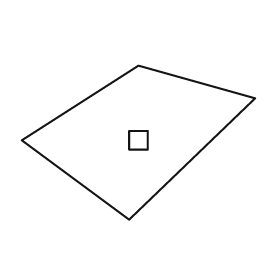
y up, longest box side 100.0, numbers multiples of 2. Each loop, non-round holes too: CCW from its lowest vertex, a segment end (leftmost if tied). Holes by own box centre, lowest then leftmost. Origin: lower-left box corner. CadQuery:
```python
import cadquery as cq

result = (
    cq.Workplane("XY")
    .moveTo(46.0, 0.0)
    .lineTo(100.0, 52.0)
    .lineTo(50.0, 66.0)
    .lineTo(0.0, 34.0)
    .close()
    .moveTo(46.0, 30.0)
    .lineTo(54.0, 30.0)
    .lineTo(54.0, 38.0)
    .lineTo(46.0, 38.0)
    .close()
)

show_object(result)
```